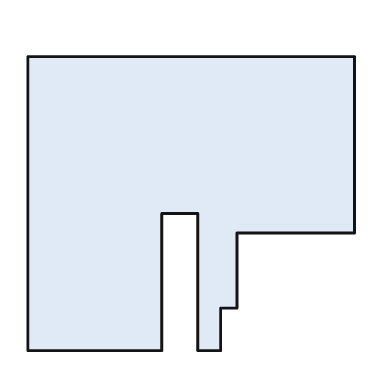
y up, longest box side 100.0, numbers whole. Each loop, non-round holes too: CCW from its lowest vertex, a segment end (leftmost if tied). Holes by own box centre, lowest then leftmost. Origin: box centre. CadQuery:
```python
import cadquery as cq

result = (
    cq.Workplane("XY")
    .moveTo(-50.0, -45.0)
    .lineTo(-9.0, -45.0)
    .lineTo(-9.0, -3.0)
    .lineTo(2.0, -3.0)
    .lineTo(2.0, -45.0)
    .lineTo(9.0, -45.0)
    .lineTo(9.0, -32.0)
    .lineTo(14.0, -32.0)
    .lineTo(14.0, -9.0)
    .lineTo(50.0, -9.0)
    .lineTo(50.0, 45.0)
    .lineTo(-50.0, 45.0)
    .close()
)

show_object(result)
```